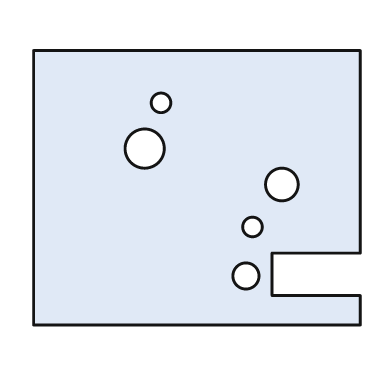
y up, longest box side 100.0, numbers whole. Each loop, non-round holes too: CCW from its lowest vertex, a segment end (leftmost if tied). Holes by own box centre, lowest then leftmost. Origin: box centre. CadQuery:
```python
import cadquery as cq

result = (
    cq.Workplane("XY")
    .moveTo(-50.0, -42.0)
    .lineTo(50.0, -42.0)
    .lineTo(50.0, -33.0)
    .lineTo(23.0, -33.0)
    .lineTo(23.0, -20.0)
    .lineTo(50.0, -20.0)
    .lineTo(50.0, 42.0)
    .lineTo(-50.0, 42.0)
    .close()
    .moveTo(15.0, -27.0)
    .circle(4.0)
    .moveTo(17.0, -12.0)
    .circle(3.0)
    .moveTo(26.0, 1.0)
    .circle(5.0)
    .moveTo(-16.0, 12.0)
    .circle(6.0)
    .moveTo(-11.0, 26.0)
    .circle(3.0)
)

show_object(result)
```